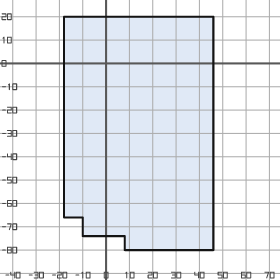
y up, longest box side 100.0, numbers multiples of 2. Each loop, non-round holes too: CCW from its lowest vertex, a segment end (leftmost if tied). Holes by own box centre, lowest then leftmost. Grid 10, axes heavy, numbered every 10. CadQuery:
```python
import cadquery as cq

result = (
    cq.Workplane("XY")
    .moveTo(8.0, -80.0)
    .lineTo(46.0, -80.0)
    .lineTo(46.0, 20.0)
    .lineTo(-18.0, 20.0)
    .lineTo(-18.0, -66.0)
    .lineTo(-10.0, -66.0)
    .lineTo(-10.0, -74.0)
    .lineTo(8.0, -74.0)
    .close()
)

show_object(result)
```